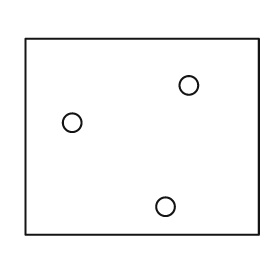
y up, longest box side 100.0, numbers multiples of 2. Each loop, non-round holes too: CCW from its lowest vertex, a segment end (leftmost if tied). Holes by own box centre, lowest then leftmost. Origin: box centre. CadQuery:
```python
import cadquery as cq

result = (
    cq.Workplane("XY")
    .moveTo(-50.0, -42.0)
    .lineTo(50.0, -42.0)
    .lineTo(50.0, 42.0)
    .lineTo(-50.0, 42.0)
    .close()
    .moveTo(10.0, -30.0)
    .circle(4.0)
    .moveTo(-30.0, 6.0)
    .circle(4.0)
    .moveTo(20.0, 22.0)
    .circle(4.0)
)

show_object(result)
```